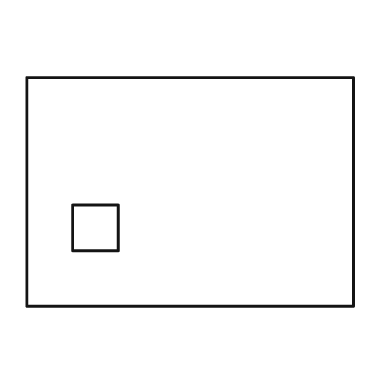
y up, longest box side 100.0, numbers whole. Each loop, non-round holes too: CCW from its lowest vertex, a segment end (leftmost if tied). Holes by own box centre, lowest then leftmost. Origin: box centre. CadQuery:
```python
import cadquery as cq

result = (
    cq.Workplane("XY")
    .moveTo(-50.0, -35.0)
    .lineTo(50.0, -35.0)
    .lineTo(50.0, 35.0)
    .lineTo(-50.0, 35.0)
    .close()
    .moveTo(-36.0, -18.0)
    .lineTo(-22.0, -18.0)
    .lineTo(-22.0, -4.0)
    .lineTo(-36.0, -4.0)
    .close()
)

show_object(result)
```